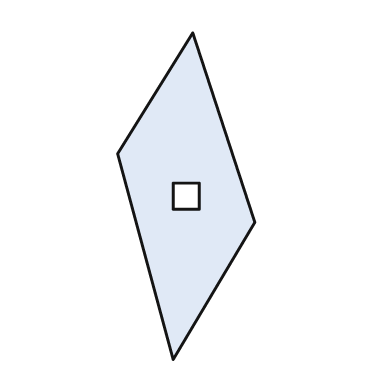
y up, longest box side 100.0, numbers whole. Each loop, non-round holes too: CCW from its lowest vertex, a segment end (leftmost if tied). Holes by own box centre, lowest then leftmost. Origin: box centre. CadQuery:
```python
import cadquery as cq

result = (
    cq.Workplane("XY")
    .moveTo(-4.0, -50.0)
    .lineTo(21.0, -8.0)
    .lineTo(2.0, 50.0)
    .lineTo(-21.0, 13.0)
    .close()
    .moveTo(-4.0, -4.0)
    .lineTo(4.0, -4.0)
    .lineTo(4.0, 4.0)
    .lineTo(-4.0, 4.0)
    .close()
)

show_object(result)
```